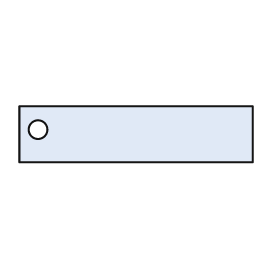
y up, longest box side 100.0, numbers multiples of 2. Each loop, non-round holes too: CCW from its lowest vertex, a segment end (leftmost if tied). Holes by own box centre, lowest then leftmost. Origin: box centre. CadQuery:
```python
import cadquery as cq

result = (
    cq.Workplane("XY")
    .moveTo(-50.0, -12.0)
    .lineTo(50.0, -12.0)
    .lineTo(50.0, 12.0)
    .lineTo(-50.0, 12.0)
    .close()
    .moveTo(-42.0, 2.0)
    .circle(4.0)
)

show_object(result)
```